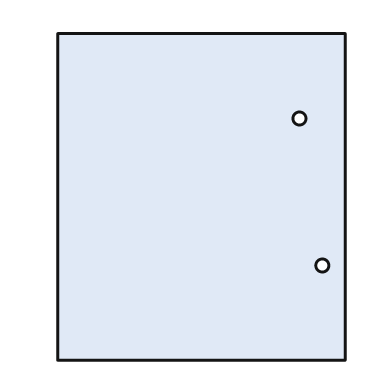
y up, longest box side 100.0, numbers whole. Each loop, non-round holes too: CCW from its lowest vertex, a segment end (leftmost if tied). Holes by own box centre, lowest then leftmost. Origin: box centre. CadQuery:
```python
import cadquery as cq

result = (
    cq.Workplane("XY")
    .moveTo(-44.0, -50.0)
    .lineTo(44.0, -50.0)
    .lineTo(44.0, 50.0)
    .lineTo(-44.0, 50.0)
    .close()
    .moveTo(37.0, -21.0)
    .circle(2.0)
    .moveTo(30.0, 24.0)
    .circle(2.0)
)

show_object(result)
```